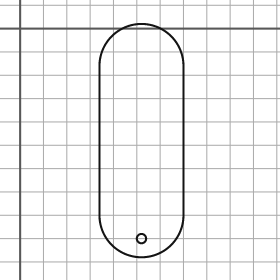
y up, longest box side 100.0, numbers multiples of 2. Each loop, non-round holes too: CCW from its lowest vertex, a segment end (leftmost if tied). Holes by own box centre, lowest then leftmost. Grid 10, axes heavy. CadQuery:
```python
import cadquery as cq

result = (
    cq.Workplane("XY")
    .moveTo(34.0, -80.0)
    .threePointArc((52.0, -98.0), (70.0, -80.0))
    .lineTo(70.0, -16.0)
    .threePointArc((52.0, 2.0), (34.0, -16.0))
    .close()
    .moveTo(52.0, -90.0)
    .circle(2.0)
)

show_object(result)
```